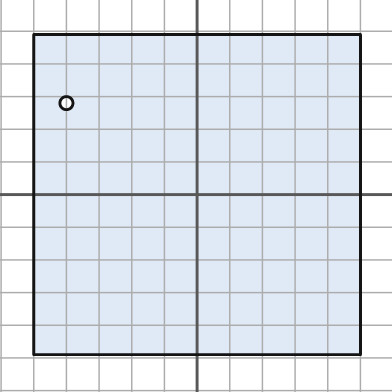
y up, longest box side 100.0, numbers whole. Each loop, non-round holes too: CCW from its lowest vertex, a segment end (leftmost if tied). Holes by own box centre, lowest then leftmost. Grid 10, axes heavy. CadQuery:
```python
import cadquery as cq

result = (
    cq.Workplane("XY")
    .moveTo(-50.0, -49.0)
    .lineTo(50.0, -49.0)
    .lineTo(50.0, 49.0)
    .lineTo(-50.0, 49.0)
    .close()
    .moveTo(-40.0, 28.0)
    .circle(2.0)
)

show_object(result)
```